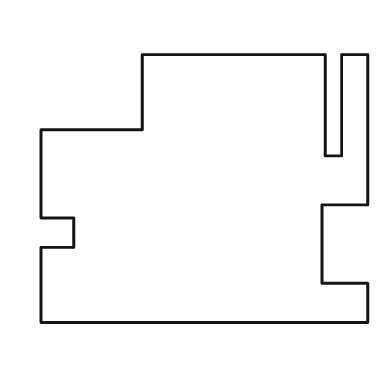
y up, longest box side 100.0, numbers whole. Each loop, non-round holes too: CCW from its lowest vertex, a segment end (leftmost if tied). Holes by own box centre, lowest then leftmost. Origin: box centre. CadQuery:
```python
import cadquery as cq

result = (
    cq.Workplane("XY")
    .moveTo(-50.0, -41.0)
    .lineTo(50.0, -41.0)
    .lineTo(50.0, -29.0)
    .lineTo(36.0, -29.0)
    .lineTo(36.0, -5.0)
    .lineTo(50.0, -5.0)
    .lineTo(50.0, 41.0)
    .lineTo(42.0, 41.0)
    .lineTo(42.0, 10.0)
    .lineTo(37.0, 10.0)
    .lineTo(37.0, 41.0)
    .lineTo(-19.0, 41.0)
    .lineTo(-19.0, 18.0)
    .lineTo(-50.0, 18.0)
    .lineTo(-50.0, -9.0)
    .lineTo(-40.0, -9.0)
    .lineTo(-40.0, -18.0)
    .lineTo(-50.0, -18.0)
    .close()
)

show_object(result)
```